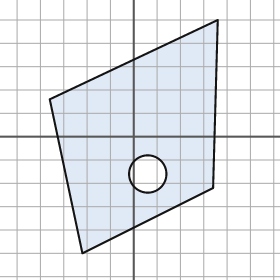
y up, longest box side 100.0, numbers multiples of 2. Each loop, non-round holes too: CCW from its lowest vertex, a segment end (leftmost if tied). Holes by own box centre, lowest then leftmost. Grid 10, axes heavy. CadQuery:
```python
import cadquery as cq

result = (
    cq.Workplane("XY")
    .moveTo(-22.0, -50.0)
    .lineTo(34.0, -22.0)
    .lineTo(36.0, 50.0)
    .lineTo(-36.0, 16.0)
    .close()
    .moveTo(6.0, -16.0)
    .circle(8.0)
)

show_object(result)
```